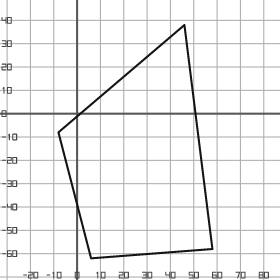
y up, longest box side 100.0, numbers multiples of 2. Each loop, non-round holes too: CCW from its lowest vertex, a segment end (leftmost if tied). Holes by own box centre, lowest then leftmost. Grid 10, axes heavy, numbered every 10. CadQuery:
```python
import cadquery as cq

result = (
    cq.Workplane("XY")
    .moveTo(6.0, -62.0)
    .lineTo(58.0, -58.0)
    .lineTo(46.0, 38.0)
    .lineTo(-8.0, -8.0)
    .close()
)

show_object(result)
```